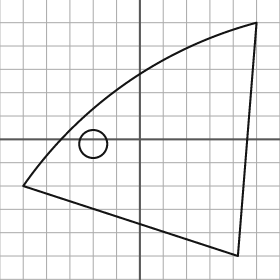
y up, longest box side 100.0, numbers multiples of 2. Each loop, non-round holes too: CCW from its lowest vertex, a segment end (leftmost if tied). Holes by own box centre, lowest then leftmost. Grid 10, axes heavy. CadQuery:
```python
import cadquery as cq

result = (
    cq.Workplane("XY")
    .moveTo(42.0, -50.0)
    .lineTo(50.0, 50.0)
    .threePointArc((-6.0, 24.0), (-50.0, -20.0))
    .close()
    .moveTo(-20.0, -2.0)
    .circle(6.0)
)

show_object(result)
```